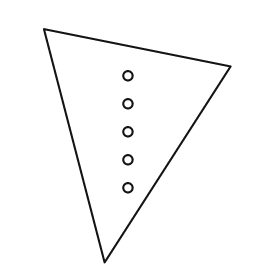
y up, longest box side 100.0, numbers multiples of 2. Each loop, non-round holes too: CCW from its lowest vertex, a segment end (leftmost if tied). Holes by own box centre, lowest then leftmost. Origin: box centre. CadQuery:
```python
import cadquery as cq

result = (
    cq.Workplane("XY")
    .moveTo(-14.0, -50.0)
    .lineTo(40.0, 34.0)
    .lineTo(-40.0, 50.0)
    .close()
    .moveTo(-4.0, -18.0)
    .circle(2.0)
    .moveTo(-4.0, -6.0)
    .circle(2.0)
    .moveTo(-4.0, 6.0)
    .circle(2.0)
    .moveTo(-4.0, 18.0)
    .circle(2.0)
    .moveTo(-4.0, 30.0)
    .circle(2.0)
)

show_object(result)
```